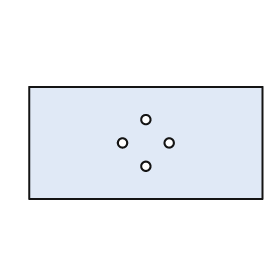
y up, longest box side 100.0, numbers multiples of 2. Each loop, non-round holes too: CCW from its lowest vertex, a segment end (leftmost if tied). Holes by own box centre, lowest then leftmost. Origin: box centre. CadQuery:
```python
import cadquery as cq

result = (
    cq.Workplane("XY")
    .moveTo(-50.0, -24.0)
    .lineTo(50.0, -24.0)
    .lineTo(50.0, 24.0)
    .lineTo(-50.0, 24.0)
    .close()
    .moveTo(0.0, -10.0)
    .circle(2.0)
    .moveTo(-10.0, 0.0)
    .circle(2.0)
    .moveTo(10.0, 0.0)
    .circle(2.0)
    .moveTo(0.0, 10.0)
    .circle(2.0)
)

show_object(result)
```